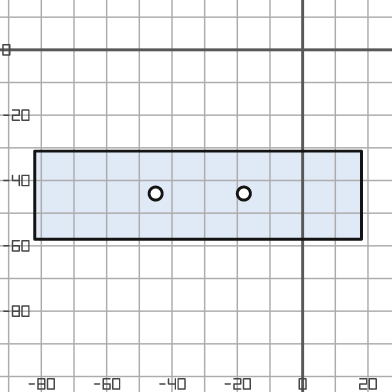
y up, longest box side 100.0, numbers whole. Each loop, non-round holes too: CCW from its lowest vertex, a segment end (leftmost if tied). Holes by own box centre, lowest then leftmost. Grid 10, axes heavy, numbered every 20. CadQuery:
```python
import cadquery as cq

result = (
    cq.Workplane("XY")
    .moveTo(-82.0, -58.0)
    .lineTo(18.0, -58.0)
    .lineTo(18.0, -31.0)
    .lineTo(-82.0, -31.0)
    .close()
    .moveTo(-45.0, -44.0)
    .circle(2.0)
    .moveTo(-18.0, -44.0)
    .circle(2.0)
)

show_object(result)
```